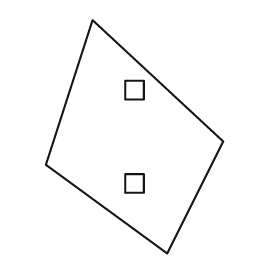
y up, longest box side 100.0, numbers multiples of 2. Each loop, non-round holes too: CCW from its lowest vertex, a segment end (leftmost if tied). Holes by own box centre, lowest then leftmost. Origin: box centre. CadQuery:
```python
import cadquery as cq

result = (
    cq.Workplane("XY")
    .moveTo(14.0, -50.0)
    .lineTo(38.0, -2.0)
    .lineTo(-18.0, 50.0)
    .lineTo(-38.0, -12.0)
    .close()
    .moveTo(-4.0, -24.0)
    .lineTo(4.0, -24.0)
    .lineTo(4.0, -16.0)
    .lineTo(-4.0, -16.0)
    .close()
    .moveTo(-4.0, 16.0)
    .lineTo(4.0, 16.0)
    .lineTo(4.0, 24.0)
    .lineTo(-4.0, 24.0)
    .close()
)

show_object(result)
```